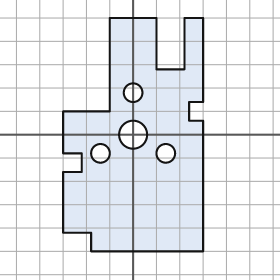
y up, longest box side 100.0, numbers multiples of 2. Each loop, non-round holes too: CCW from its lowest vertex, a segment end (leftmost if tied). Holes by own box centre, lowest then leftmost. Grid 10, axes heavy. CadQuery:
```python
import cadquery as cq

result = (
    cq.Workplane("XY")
    .moveTo(-18.0, -50.0)
    .lineTo(30.0, -50.0)
    .lineTo(30.0, 6.0)
    .lineTo(24.0, 6.0)
    .lineTo(24.0, 14.0)
    .lineTo(30.0, 14.0)
    .lineTo(30.0, 50.0)
    .lineTo(22.0, 50.0)
    .lineTo(22.0, 28.0)
    .lineTo(10.0, 28.0)
    .lineTo(10.0, 50.0)
    .lineTo(-10.0, 50.0)
    .lineTo(-10.0, 10.0)
    .lineTo(-30.0, 10.0)
    .lineTo(-30.0, -8.0)
    .lineTo(-22.0, -8.0)
    .lineTo(-22.0, -16.0)
    .lineTo(-30.0, -16.0)
    .lineTo(-30.0, -42.0)
    .lineTo(-18.0, -42.0)
    .close()
    .moveTo(-14.0, -8.0)
    .circle(4.0)
    .moveTo(14.0, -8.0)
    .circle(4.0)
    .moveTo(0.0, 0.0)
    .circle(6.0)
    .moveTo(0.0, 18.0)
    .circle(4.0)
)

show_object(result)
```